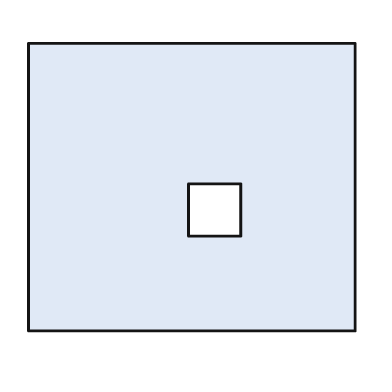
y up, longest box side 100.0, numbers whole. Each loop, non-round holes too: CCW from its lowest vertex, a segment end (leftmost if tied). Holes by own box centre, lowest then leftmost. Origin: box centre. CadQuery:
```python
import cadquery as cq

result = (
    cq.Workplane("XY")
    .moveTo(-50.0, -44.0)
    .lineTo(50.0, -44.0)
    .lineTo(50.0, 44.0)
    .lineTo(-50.0, 44.0)
    .close()
    .moveTo(-1.0, -15.0)
    .lineTo(15.0, -15.0)
    .lineTo(15.0, 1.0)
    .lineTo(-1.0, 1.0)
    .close()
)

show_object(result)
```